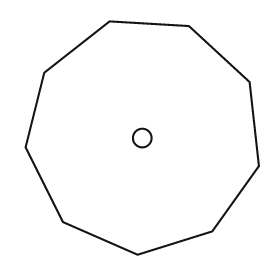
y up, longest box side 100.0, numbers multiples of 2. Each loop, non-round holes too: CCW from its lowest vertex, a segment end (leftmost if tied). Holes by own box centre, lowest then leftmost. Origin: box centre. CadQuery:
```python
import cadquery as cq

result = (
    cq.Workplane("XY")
    .moveTo(-2.0, -50.0)
    .lineTo(30.0, -40.0)
    .lineTo(50.0, -12.0)
    .lineTo(46.0, 24.0)
    .lineTo(20.0, 48.0)
    .lineTo(-14.0, 50.0)
    .lineTo(-42.0, 28.0)
    .lineTo(-50.0, -4.0)
    .lineTo(-34.0, -36.0)
    .close()
    .moveTo(0.0, 0.0)
    .circle(4.0)
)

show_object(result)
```